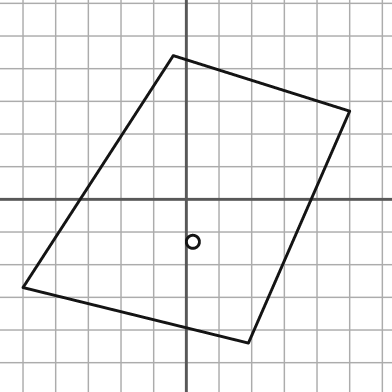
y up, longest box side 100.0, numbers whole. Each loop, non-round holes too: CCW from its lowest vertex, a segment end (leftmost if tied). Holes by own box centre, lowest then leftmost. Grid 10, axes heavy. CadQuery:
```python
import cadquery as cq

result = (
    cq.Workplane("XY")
    .moveTo(19.0, -44.0)
    .lineTo(50.0, 27.0)
    .lineTo(-4.0, 44.0)
    .lineTo(-50.0, -27.0)
    .close()
    .moveTo(2.0, -13.0)
    .circle(2.0)
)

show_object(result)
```